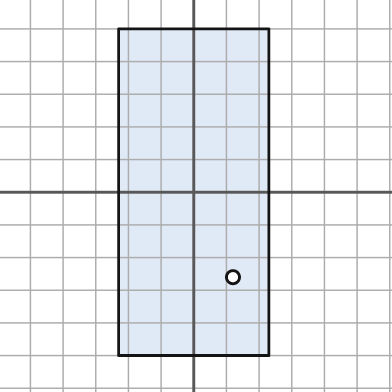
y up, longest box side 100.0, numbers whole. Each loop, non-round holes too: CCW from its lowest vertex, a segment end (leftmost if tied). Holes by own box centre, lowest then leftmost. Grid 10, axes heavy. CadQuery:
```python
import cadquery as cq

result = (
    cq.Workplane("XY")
    .moveTo(-23.0, -50.0)
    .lineTo(23.0, -50.0)
    .lineTo(23.0, 50.0)
    .lineTo(-23.0, 50.0)
    .close()
    .moveTo(12.0, -26.0)
    .circle(2.0)
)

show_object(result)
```